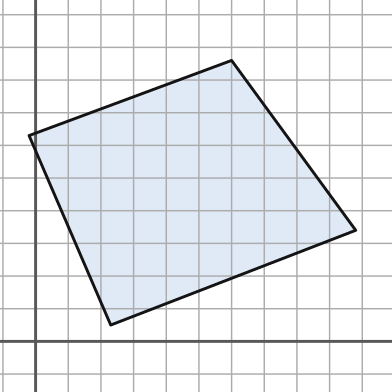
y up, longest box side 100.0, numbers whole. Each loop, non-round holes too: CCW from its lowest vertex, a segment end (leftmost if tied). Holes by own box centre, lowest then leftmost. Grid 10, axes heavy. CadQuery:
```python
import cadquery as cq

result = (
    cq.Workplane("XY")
    .moveTo(23.0, 5.0)
    .lineTo(98.0, 34.0)
    .lineTo(60.0, 86.0)
    .lineTo(-2.0, 63.0)
    .close()
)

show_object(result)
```